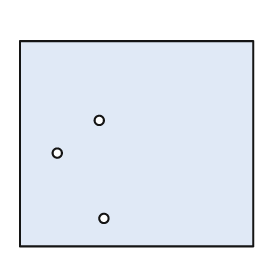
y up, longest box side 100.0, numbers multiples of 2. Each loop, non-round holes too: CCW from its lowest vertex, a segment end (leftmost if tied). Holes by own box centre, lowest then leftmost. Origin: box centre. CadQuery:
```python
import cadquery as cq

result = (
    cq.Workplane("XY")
    .moveTo(-50.0, -44.0)
    .lineTo(50.0, -44.0)
    .lineTo(50.0, 44.0)
    .lineTo(-50.0, 44.0)
    .close()
    .moveTo(-14.0, -32.0)
    .circle(2.0)
    .moveTo(-34.0, -4.0)
    .circle(2.0)
    .moveTo(-16.0, 10.0)
    .circle(2.0)
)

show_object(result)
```